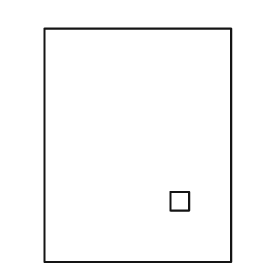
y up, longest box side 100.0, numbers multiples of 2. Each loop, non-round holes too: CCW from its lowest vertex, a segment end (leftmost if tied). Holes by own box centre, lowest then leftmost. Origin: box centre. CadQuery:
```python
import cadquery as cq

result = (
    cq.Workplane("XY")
    .moveTo(-40.0, -50.0)
    .lineTo(40.0, -50.0)
    .lineTo(40.0, 50.0)
    .lineTo(-40.0, 50.0)
    .close()
    .moveTo(14.0, -28.0)
    .lineTo(22.0, -28.0)
    .lineTo(22.0, -20.0)
    .lineTo(14.0, -20.0)
    .close()
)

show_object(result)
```